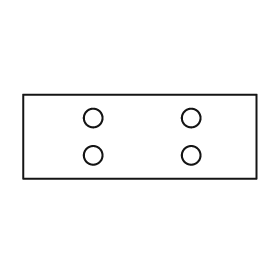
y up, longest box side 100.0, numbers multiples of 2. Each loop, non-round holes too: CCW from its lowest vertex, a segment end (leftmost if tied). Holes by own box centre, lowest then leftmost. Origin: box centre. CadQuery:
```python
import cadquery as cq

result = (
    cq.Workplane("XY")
    .moveTo(-50.0, -18.0)
    .lineTo(50.0, -18.0)
    .lineTo(50.0, 18.0)
    .lineTo(-50.0, 18.0)
    .close()
    .moveTo(-20.0, -8.0)
    .circle(4.0)
    .moveTo(22.0, -8.0)
    .circle(4.0)
    .moveTo(-20.0, 8.0)
    .circle(4.0)
    .moveTo(22.0, 8.0)
    .circle(4.0)
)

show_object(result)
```